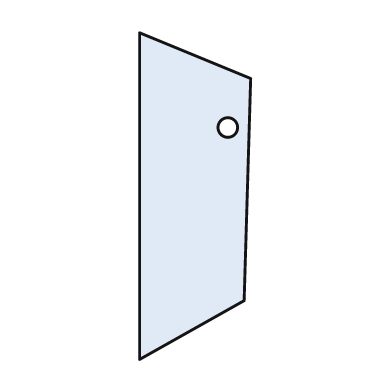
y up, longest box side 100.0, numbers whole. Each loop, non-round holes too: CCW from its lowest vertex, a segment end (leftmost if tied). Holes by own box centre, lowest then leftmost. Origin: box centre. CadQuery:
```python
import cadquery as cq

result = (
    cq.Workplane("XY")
    .moveTo(-17.0, -50.0)
    .lineTo(15.0, -32.0)
    .lineTo(17.0, 36.0)
    .lineTo(-17.0, 50.0)
    .close()
    .moveTo(10.0, 21.0)
    .circle(3.0)
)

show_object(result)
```